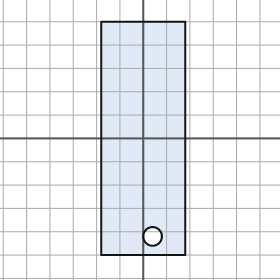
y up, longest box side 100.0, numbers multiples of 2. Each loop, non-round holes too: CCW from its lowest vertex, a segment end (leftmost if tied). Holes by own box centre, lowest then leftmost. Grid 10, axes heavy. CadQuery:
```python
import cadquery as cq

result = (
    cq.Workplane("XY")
    .moveTo(-18.0, -50.0)
    .lineTo(18.0, -50.0)
    .lineTo(18.0, 50.0)
    .lineTo(-18.0, 50.0)
    .close()
    .moveTo(4.0, -42.0)
    .circle(4.0)
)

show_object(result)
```